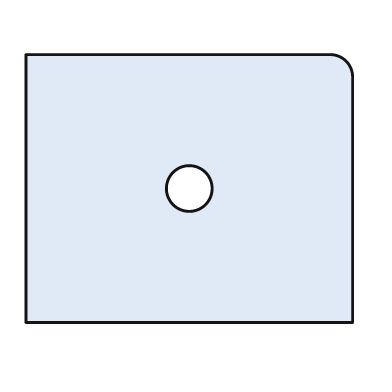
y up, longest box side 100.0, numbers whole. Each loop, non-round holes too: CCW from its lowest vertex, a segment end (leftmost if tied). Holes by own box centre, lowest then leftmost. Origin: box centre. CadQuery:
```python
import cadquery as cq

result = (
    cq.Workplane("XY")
    .moveTo(-50.0, -41.0)
    .lineTo(50.0, -41.0)
    .lineTo(50.0, 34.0)
    .threePointArc((48.0, 39.0), (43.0, 41.0))
    .lineTo(-50.0, 41.0)
    .close()
    .moveTo(0.0, 0.0)
    .circle(7.0)
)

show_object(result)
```